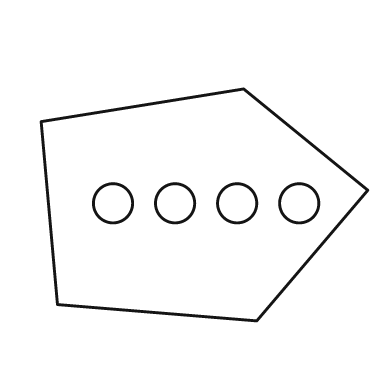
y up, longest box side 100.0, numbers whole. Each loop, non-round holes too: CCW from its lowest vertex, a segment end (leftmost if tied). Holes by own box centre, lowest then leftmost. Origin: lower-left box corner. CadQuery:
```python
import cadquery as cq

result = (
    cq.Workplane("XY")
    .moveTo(66.0, 0.0)
    .lineTo(100.0, 40.0)
    .lineTo(62.0, 71.0)
    .lineTo(0.0, 61.0)
    .lineTo(5.0, 5.0)
    .close()
    .moveTo(22.0, 36.0)
    .circle(6.0)
    .moveTo(41.0, 36.0)
    .circle(6.0)
    .moveTo(60.0, 36.0)
    .circle(6.0)
    .moveTo(79.0, 36.0)
    .circle(6.0)
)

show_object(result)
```